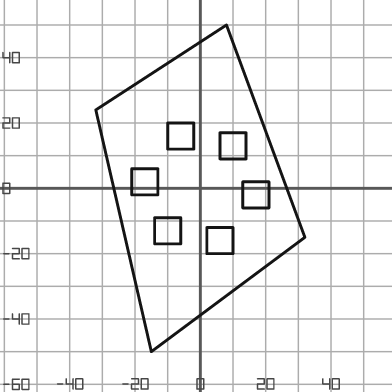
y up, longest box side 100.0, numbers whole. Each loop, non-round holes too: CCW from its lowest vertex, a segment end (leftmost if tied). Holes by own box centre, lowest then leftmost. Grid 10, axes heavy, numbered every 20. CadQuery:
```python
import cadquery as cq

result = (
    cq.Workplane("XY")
    .moveTo(-15.0, -50.0)
    .lineTo(32.0, -15.0)
    .lineTo(8.0, 50.0)
    .lineTo(-32.0, 24.0)
    .close()
    .moveTo(2.0, -20.0)
    .lineTo(10.0, -20.0)
    .lineTo(10.0, -12.0)
    .lineTo(2.0, -12.0)
    .close()
    .moveTo(-14.0, -17.0)
    .lineTo(-6.0, -17.0)
    .lineTo(-6.0, -9.0)
    .lineTo(-14.0, -9.0)
    .close()
    .moveTo(13.0, -6.0)
    .lineTo(21.0, -6.0)
    .lineTo(21.0, 2.0)
    .lineTo(13.0, 2.0)
    .close()
    .moveTo(-21.0, -2.0)
    .lineTo(-13.0, -2.0)
    .lineTo(-13.0, 6.0)
    .lineTo(-21.0, 6.0)
    .close()
    .moveTo(6.0, 9.0)
    .lineTo(14.0, 9.0)
    .lineTo(14.0, 17.0)
    .lineTo(6.0, 17.0)
    .close()
    .moveTo(-10.0, 12.0)
    .lineTo(-2.0, 12.0)
    .lineTo(-2.0, 20.0)
    .lineTo(-10.0, 20.0)
    .close()
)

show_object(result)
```